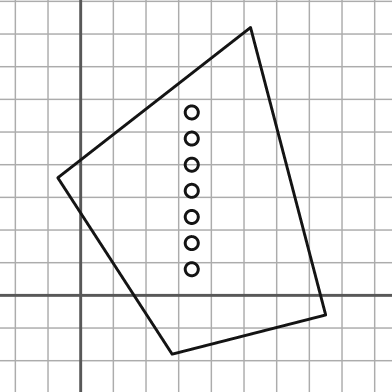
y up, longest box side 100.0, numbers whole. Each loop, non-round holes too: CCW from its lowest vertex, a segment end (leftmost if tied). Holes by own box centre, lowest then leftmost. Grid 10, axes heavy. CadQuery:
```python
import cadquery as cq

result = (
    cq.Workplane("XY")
    .moveTo(28.0, -18.0)
    .lineTo(75.0, -6.0)
    .lineTo(52.0, 82.0)
    .lineTo(-7.0, 36.0)
    .close()
    .moveTo(34.0, 8.0)
    .circle(2.0)
    .moveTo(34.0, 16.0)
    .circle(2.0)
    .moveTo(34.0, 24.0)
    .circle(2.0)
    .moveTo(34.0, 32.0)
    .circle(2.0)
    .moveTo(34.0, 40.0)
    .circle(2.0)
    .moveTo(34.0, 48.0)
    .circle(2.0)
    .moveTo(34.0, 56.0)
    .circle(2.0)
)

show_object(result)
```